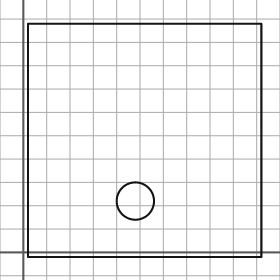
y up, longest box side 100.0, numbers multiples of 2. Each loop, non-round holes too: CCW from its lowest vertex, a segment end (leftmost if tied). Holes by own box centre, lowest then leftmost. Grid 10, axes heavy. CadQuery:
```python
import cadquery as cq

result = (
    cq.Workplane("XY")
    .moveTo(2.0, -2.0)
    .lineTo(102.0, -2.0)
    .lineTo(102.0, 98.0)
    .lineTo(2.0, 98.0)
    .close()
    .moveTo(48.0, 22.0)
    .circle(8.0)
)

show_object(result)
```